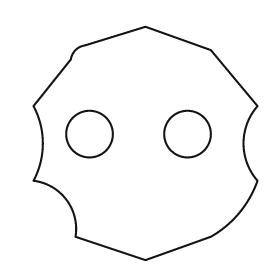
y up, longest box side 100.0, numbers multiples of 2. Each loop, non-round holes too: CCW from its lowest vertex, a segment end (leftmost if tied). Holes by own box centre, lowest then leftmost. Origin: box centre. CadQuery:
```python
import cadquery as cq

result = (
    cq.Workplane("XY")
    .moveTo(0.0, -50.0)
    .lineTo(28.0, -40.0)
    .threePointArc((40.0, -30.0), (48.0, -16.0))
    .threePointArc((42.0, 0.0), (48.0, 16.0))
    .lineTo(28.0, 40.0)
    .lineTo(0.0, 50.0)
    .lineTo(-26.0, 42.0)
    .threePointArc((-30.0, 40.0), (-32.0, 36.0))
    .lineTo(-48.0, 16.0)
    .threePointArc((-44.0, 0.0), (-48.0, -16.0))
    .threePointArc((-34.0, -24.0), (-30.0, -40.0))
    .close()
    .moveTo(-24.0, 4.0)
    .circle(10.0)
    .moveTo(18.0, 4.0)
    .circle(10.0)
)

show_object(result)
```